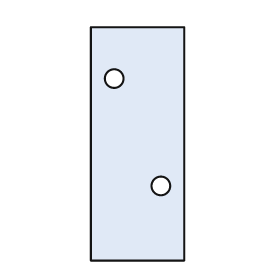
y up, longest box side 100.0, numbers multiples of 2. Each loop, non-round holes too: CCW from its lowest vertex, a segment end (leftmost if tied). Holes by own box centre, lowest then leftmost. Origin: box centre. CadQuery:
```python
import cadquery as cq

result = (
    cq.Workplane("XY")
    .moveTo(-20.0, -50.0)
    .lineTo(20.0, -50.0)
    .lineTo(20.0, 50.0)
    .lineTo(-20.0, 50.0)
    .close()
    .moveTo(10.0, -18.0)
    .circle(4.0)
    .moveTo(-10.0, 28.0)
    .circle(4.0)
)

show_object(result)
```